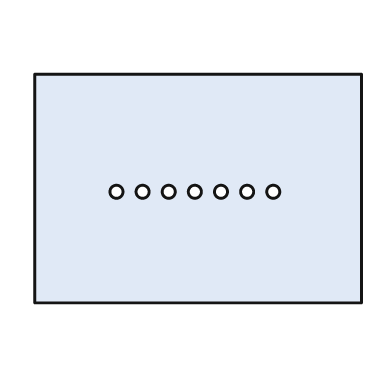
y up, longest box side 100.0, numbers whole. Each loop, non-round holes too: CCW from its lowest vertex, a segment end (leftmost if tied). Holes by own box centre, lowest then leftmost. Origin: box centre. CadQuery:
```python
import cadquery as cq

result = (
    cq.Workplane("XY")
    .moveTo(-50.0, -35.0)
    .lineTo(50.0, -35.0)
    .lineTo(50.0, 35.0)
    .lineTo(-50.0, 35.0)
    .close()
    .moveTo(-25.0, -1.0)
    .circle(2.0)
    .moveTo(-17.0, -1.0)
    .circle(2.0)
    .moveTo(-9.0, -1.0)
    .circle(2.0)
    .moveTo(-1.0, -1.0)
    .circle(2.0)
    .moveTo(7.0, -1.0)
    .circle(2.0)
    .moveTo(15.0, -1.0)
    .circle(2.0)
    .moveTo(23.0, -1.0)
    .circle(2.0)
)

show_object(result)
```